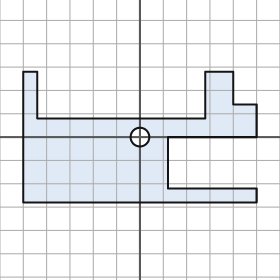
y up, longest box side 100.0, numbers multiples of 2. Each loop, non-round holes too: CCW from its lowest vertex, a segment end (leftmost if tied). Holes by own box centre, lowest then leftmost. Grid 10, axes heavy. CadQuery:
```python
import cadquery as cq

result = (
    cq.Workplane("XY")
    .moveTo(-50.0, -28.0)
    .lineTo(50.0, -28.0)
    .lineTo(50.0, -22.0)
    .lineTo(12.0, -22.0)
    .lineTo(12.0, 0.0)
    .lineTo(50.0, 0.0)
    .lineTo(50.0, 14.0)
    .lineTo(40.0, 14.0)
    .lineTo(40.0, 28.0)
    .lineTo(28.0, 28.0)
    .lineTo(28.0, 8.0)
    .lineTo(-44.0, 8.0)
    .lineTo(-44.0, 28.0)
    .lineTo(-50.0, 28.0)
    .close()
    .moveTo(0.0, 0.0)
    .circle(4.0)
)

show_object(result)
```